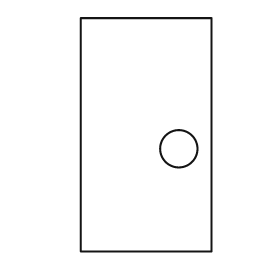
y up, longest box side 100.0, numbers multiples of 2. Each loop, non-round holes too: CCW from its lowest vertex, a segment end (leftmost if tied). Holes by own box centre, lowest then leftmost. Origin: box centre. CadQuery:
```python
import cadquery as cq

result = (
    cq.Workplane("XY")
    .moveTo(-28.0, -50.0)
    .lineTo(28.0, -50.0)
    .lineTo(28.0, 50.0)
    .lineTo(-28.0, 50.0)
    .close()
    .moveTo(14.0, -6.0)
    .circle(8.0)
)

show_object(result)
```